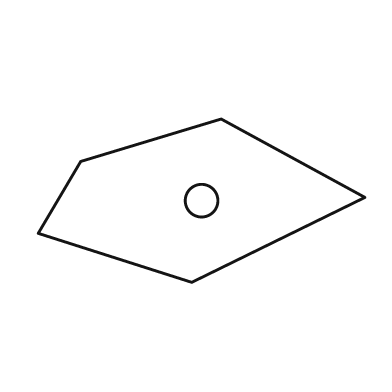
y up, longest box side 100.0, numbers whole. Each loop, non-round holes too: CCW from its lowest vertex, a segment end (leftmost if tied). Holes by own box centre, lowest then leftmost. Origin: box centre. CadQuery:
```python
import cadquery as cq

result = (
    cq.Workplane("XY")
    .moveTo(-3.0, -25.0)
    .lineTo(50.0, 1.0)
    .lineTo(6.0, 25.0)
    .lineTo(-37.0, 12.0)
    .lineTo(-50.0, -10.0)
    .close()
    .moveTo(0.0, 0.0)
    .circle(5.0)
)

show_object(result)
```